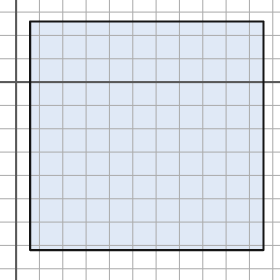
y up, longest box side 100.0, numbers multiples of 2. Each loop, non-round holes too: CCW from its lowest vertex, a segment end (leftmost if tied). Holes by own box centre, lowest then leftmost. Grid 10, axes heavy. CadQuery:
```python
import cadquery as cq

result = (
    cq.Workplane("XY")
    .moveTo(6.0, -72.0)
    .lineTo(106.0, -72.0)
    .lineTo(106.0, 26.0)
    .lineTo(6.0, 26.0)
    .close()
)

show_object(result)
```